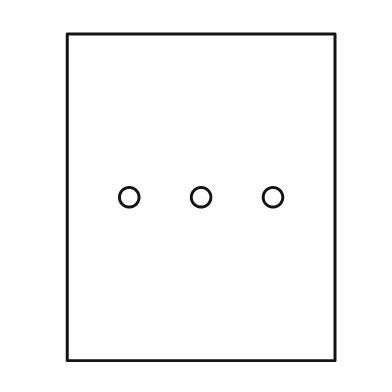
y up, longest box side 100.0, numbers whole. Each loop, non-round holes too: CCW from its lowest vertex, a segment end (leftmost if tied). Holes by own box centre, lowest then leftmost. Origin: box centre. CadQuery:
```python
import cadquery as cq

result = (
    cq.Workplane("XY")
    .moveTo(-41.0, -50.0)
    .lineTo(41.0, -50.0)
    .lineTo(41.0, 50.0)
    .lineTo(-41.0, 50.0)
    .close()
    .moveTo(-22.0, 0.0)
    .circle(3.0)
    .moveTo(0.0, 0.0)
    .circle(3.0)
    .moveTo(22.0, 0.0)
    .circle(3.0)
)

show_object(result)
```